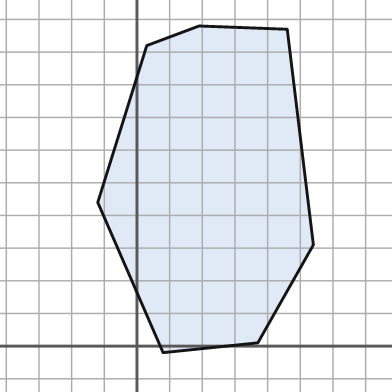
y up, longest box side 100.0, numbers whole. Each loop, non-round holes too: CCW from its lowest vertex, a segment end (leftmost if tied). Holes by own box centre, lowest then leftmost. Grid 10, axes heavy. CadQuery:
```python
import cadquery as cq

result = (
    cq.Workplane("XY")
    .moveTo(8.0, -2.0)
    .lineTo(37.0, 1.0)
    .lineTo(54.0, 31.0)
    .lineTo(46.0, 97.0)
    .lineTo(19.0, 98.0)
    .lineTo(3.0, 92.0)
    .lineTo(-12.0, 44.0)
    .close()
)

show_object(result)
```